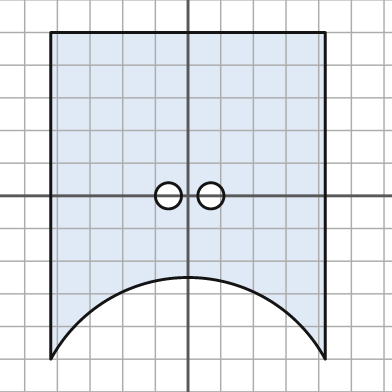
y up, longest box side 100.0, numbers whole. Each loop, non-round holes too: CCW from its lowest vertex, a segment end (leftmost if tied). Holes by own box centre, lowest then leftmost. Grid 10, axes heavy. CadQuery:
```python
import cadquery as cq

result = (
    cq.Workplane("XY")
    .moveTo(-42.0, -50.0)
    .threePointArc((0.0, -25.0), (42.0, -50.0))
    .lineTo(42.0, 50.0)
    .lineTo(-42.0, 50.0)
    .close()
    .moveTo(-6.0, 0.0)
    .circle(4.0)
    .moveTo(7.0, 0.0)
    .circle(4.0)
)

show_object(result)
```